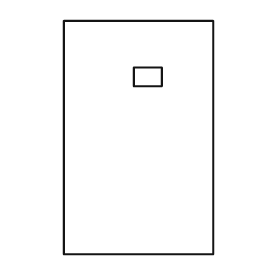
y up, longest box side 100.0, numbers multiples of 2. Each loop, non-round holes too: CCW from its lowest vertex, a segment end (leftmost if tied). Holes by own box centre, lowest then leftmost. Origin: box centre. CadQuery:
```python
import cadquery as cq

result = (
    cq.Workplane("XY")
    .moveTo(-32.0, -50.0)
    .lineTo(32.0, -50.0)
    .lineTo(32.0, 50.0)
    .lineTo(-32.0, 50.0)
    .close()
    .moveTo(-2.0, 22.0)
    .lineTo(10.0, 22.0)
    .lineTo(10.0, 30.0)
    .lineTo(-2.0, 30.0)
    .close()
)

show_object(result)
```